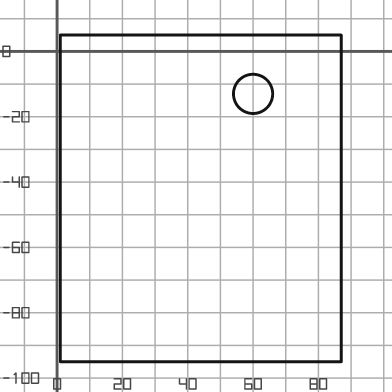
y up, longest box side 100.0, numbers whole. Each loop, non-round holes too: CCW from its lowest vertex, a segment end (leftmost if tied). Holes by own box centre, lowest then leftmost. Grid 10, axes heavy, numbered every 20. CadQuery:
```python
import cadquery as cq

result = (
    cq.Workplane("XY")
    .moveTo(1.0, -95.0)
    .lineTo(87.0, -95.0)
    .lineTo(87.0, 5.0)
    .lineTo(1.0, 5.0)
    .close()
    .moveTo(60.0, -13.0)
    .circle(6.0)
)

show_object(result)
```